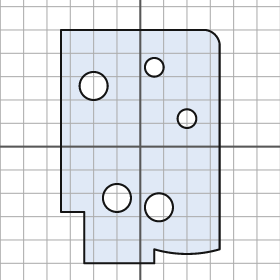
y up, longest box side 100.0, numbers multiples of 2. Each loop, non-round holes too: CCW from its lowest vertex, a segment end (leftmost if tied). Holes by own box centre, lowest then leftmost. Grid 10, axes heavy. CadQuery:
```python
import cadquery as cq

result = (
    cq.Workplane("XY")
    .moveTo(-24.0, -50.0)
    .lineTo(6.0, -50.0)
    .lineTo(6.0, -44.0)
    .threePointArc((20.0, -46.0), (34.0, -44.0))
    .lineTo(34.0, 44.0)
    .threePointArc((32.0, 48.0), (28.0, 50.0))
    .lineTo(-34.0, 50.0)
    .lineTo(-34.0, -28.0)
    .lineTo(-24.0, -28.0)
    .close()
    .moveTo(8.0, -26.0)
    .circle(6.0)
    .moveTo(-10.0, -22.0)
    .circle(6.0)
    .moveTo(20.0, 12.0)
    .circle(4.0)
    .moveTo(-20.0, 26.0)
    .circle(6.0)
    .moveTo(6.0, 34.0)
    .circle(4.0)
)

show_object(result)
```